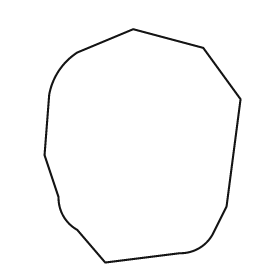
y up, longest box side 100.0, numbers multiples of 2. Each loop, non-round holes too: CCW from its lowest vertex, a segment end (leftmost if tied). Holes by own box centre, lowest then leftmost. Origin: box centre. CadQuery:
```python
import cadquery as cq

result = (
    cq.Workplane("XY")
    .moveTo(-16.0, -50.0)
    .lineTo(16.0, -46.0)
    .threePointArc((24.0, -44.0), (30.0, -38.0))
    .lineTo(36.0, -26.0)
    .lineTo(42.0, 20.0)
    .lineTo(26.0, 42.0)
    .lineTo(-4.0, 50.0)
    .lineTo(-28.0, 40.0)
    .threePointArc((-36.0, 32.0), (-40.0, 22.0))
    .lineTo(-42.0, -4.0)
    .lineTo(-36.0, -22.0)
    .threePointArc((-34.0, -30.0), (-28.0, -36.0))
    .close()
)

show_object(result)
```